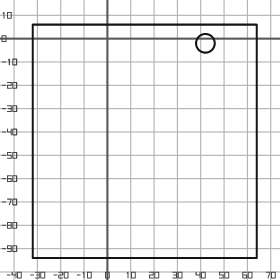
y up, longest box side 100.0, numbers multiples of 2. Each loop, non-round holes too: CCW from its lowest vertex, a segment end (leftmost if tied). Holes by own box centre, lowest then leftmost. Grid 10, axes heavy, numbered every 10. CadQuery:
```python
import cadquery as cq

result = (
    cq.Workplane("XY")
    .moveTo(-32.0, -94.0)
    .lineTo(64.0, -94.0)
    .lineTo(64.0, 6.0)
    .lineTo(-32.0, 6.0)
    .close()
    .moveTo(42.0, -2.0)
    .circle(4.0)
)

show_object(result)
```